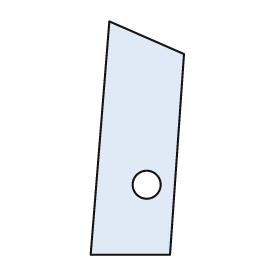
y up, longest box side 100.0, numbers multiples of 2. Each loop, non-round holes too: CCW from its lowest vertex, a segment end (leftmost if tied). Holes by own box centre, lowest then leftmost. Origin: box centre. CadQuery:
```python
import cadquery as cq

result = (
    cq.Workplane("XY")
    .moveTo(-20.0, -50.0)
    .lineTo(14.0, -50.0)
    .lineTo(20.0, 36.0)
    .lineTo(-12.0, 50.0)
    .close()
    .moveTo(4.0, -20.0)
    .circle(6.0)
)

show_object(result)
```